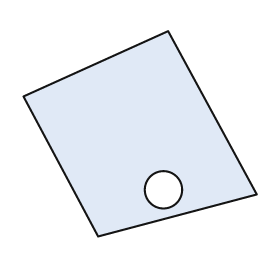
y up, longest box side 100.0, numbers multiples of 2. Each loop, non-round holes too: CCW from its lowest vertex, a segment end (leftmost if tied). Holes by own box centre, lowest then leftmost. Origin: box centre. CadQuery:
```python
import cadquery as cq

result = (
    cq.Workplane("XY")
    .moveTo(-18.0, -44.0)
    .lineTo(50.0, -26.0)
    .lineTo(12.0, 44.0)
    .lineTo(-50.0, 16.0)
    .close()
    .moveTo(10.0, -24.0)
    .circle(8.0)
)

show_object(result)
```